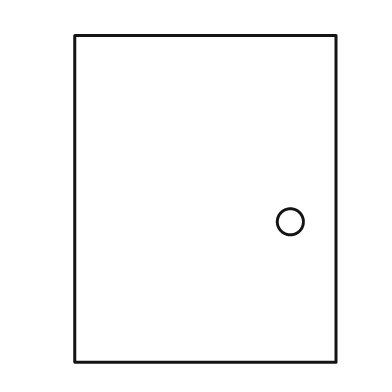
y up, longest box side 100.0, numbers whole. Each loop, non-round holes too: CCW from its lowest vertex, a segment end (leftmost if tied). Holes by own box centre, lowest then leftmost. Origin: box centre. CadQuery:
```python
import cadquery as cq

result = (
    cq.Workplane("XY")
    .moveTo(-40.0, -50.0)
    .lineTo(40.0, -50.0)
    .lineTo(40.0, 50.0)
    .lineTo(-40.0, 50.0)
    .close()
    .moveTo(26.0, -7.0)
    .circle(4.0)
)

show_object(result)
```